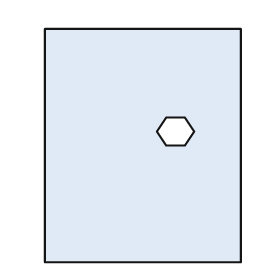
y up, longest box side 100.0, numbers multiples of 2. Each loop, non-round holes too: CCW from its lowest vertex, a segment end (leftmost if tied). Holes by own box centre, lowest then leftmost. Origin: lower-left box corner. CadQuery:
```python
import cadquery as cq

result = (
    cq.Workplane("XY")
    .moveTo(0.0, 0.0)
    .lineTo(84.0, 0.0)
    .lineTo(84.0, 100.0)
    .lineTo(0.0, 100.0)
    .close()
    .moveTo(52.0, 50.0)
    .lineTo(60.0, 50.0)
    .lineTo(64.0, 56.0)
    .lineTo(60.0, 62.0)
    .lineTo(52.0, 62.0)
    .lineTo(48.0, 56.0)
    .close()
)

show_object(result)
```